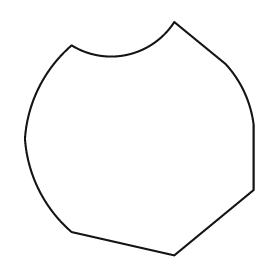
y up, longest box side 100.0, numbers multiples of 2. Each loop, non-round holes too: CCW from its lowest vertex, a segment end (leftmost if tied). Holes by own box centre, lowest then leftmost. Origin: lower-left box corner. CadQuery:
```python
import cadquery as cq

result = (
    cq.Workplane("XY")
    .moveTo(64.0, 0.0)
    .lineTo(98.0, 28.0)
    .lineTo(98.0, 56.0)
    .threePointArc((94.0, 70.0), (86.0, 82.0))
    .lineTo(64.0, 100.0)
    .threePointArc((44.0, 86.0), (20.0, 90.0))
    .threePointArc((6.0, 72.0), (0.0, 50.0))
    .threePointArc((6.0, 28.0), (20.0, 10.0))
    .close()
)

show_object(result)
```